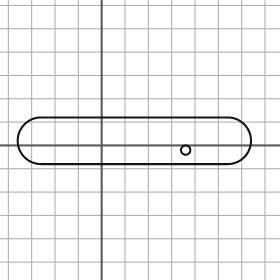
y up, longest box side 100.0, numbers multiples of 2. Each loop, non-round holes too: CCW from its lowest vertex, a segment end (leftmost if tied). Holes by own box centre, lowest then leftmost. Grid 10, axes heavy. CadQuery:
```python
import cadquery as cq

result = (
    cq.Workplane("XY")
    .moveTo(-26.0, -8.0)
    .lineTo(54.0, -8.0)
    .threePointArc((64.0, 2.0), (54.0, 12.0))
    .lineTo(-26.0, 12.0)
    .threePointArc((-36.0, 2.0), (-26.0, -8.0))
    .close()
    .moveTo(36.0, -2.0)
    .circle(2.0)
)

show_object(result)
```